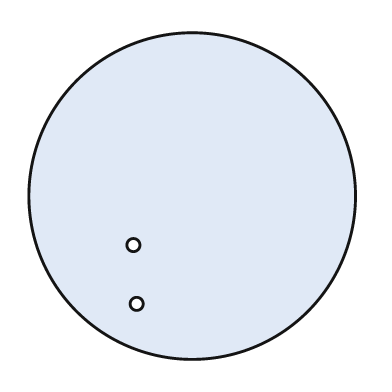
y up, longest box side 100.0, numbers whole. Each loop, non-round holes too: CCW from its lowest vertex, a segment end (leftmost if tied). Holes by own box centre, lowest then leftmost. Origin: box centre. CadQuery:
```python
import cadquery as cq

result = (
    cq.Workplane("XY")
    .moveTo(0.0, 0.0)
    .circle(50.0)
    .moveTo(-17.0, -33.0)
    .circle(2.0)
    .moveTo(-18.0, -15.0)
    .circle(2.0)
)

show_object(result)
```